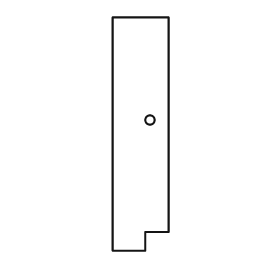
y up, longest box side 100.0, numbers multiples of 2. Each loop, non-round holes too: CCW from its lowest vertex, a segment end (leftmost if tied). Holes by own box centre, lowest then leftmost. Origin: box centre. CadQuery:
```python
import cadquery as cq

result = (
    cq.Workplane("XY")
    .moveTo(-12.0, -50.0)
    .lineTo(2.0, -50.0)
    .lineTo(2.0, -42.0)
    .lineTo(12.0, -42.0)
    .lineTo(12.0, 50.0)
    .lineTo(-12.0, 50.0)
    .close()
    .moveTo(4.0, 6.0)
    .circle(2.0)
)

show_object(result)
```